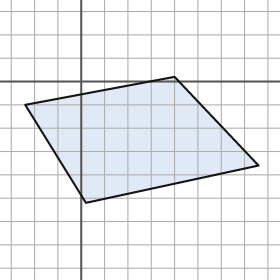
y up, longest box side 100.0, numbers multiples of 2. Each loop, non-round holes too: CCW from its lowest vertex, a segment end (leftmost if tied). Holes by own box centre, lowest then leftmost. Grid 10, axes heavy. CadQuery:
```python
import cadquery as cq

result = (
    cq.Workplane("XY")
    .moveTo(2.0, -52.0)
    .lineTo(76.0, -36.0)
    .lineTo(40.0, 2.0)
    .lineTo(-24.0, -10.0)
    .close()
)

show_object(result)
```